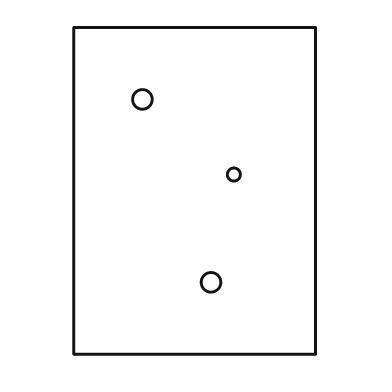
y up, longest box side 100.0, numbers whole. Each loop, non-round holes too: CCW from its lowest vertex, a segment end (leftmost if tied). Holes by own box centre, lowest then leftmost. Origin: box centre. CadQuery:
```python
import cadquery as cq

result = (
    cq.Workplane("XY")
    .moveTo(-37.0, -50.0)
    .lineTo(37.0, -50.0)
    .lineTo(37.0, 50.0)
    .lineTo(-37.0, 50.0)
    .close()
    .moveTo(5.0, -28.0)
    .circle(3.0)
    .moveTo(12.0, 5.0)
    .circle(2.0)
    .moveTo(-16.0, 28.0)
    .circle(3.0)
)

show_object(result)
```